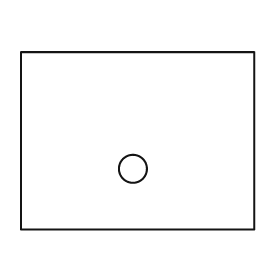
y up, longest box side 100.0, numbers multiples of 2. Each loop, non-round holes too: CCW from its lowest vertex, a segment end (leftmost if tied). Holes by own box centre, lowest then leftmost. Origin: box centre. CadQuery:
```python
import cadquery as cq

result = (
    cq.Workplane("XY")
    .moveTo(-50.0, -38.0)
    .lineTo(50.0, -38.0)
    .lineTo(50.0, 38.0)
    .lineTo(-50.0, 38.0)
    .close()
    .moveTo(-2.0, -12.0)
    .circle(6.0)
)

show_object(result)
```